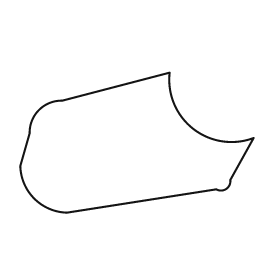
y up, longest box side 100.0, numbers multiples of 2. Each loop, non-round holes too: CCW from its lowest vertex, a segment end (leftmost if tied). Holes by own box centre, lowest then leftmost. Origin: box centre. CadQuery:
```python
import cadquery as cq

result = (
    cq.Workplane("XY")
    .moveTo(-30.0, -30.0)
    .lineTo(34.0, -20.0)
    .threePointArc((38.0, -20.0), (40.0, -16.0))
    .lineTo(50.0, 2.0)
    .threePointArc((24.0, 6.0), (14.0, 30.0))
    .lineTo(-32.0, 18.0)
    .threePointArc((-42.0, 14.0), (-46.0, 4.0))
    .lineTo(-50.0, -10.0)
    .threePointArc((-44.0, -24.0), (-30.0, -30.0))
    .close()
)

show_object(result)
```